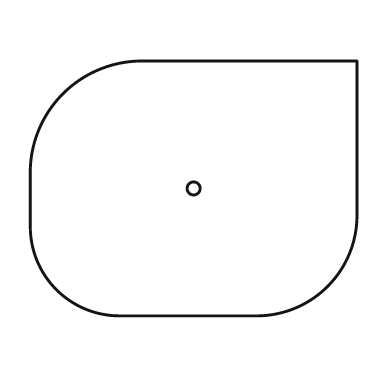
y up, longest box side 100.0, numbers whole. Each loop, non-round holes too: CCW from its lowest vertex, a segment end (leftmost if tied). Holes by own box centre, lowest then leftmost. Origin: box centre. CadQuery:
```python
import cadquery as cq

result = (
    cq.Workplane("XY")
    .moveTo(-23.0, -39.0)
    .lineTo(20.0, -39.0)
    .threePointArc((41.0, -30.0), (50.0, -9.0))
    .lineTo(50.0, 39.0)
    .lineTo(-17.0, 39.0)
    .threePointArc((-40.0, 29.0), (-50.0, 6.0))
    .lineTo(-50.0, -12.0)
    .threePointArc((-42.0, -31.0), (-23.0, -39.0))
    .close()
    .moveTo(0.0, 0.0)
    .circle(2.0)
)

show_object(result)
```